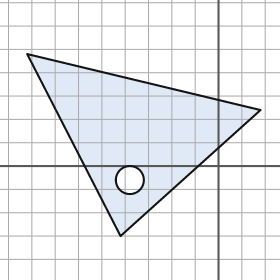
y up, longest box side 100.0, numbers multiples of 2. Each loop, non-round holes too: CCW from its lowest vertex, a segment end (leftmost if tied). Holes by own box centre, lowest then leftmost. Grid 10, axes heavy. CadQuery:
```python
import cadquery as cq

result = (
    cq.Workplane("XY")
    .moveTo(-42.0, -30.0)
    .lineTo(18.0, 24.0)
    .lineTo(-82.0, 48.0)
    .close()
    .moveTo(-38.0, -6.0)
    .circle(6.0)
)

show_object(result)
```